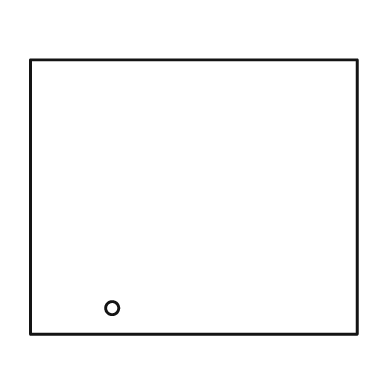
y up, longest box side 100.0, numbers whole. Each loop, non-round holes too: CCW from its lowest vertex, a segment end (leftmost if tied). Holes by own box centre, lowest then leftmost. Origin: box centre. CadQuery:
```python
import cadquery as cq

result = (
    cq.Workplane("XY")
    .moveTo(-50.0, -42.0)
    .lineTo(50.0, -42.0)
    .lineTo(50.0, 42.0)
    .lineTo(-50.0, 42.0)
    .close()
    .moveTo(-25.0, -34.0)
    .circle(2.0)
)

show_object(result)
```